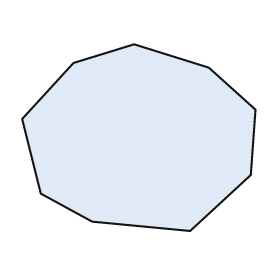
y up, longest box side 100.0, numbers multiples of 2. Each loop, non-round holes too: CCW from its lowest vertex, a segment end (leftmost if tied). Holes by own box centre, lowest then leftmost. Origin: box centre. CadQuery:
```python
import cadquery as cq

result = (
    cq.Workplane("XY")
    .moveTo(22.0, -40.0)
    .lineTo(48.0, -16.0)
    .lineTo(50.0, 12.0)
    .lineTo(30.0, 30.0)
    .lineTo(-2.0, 40.0)
    .lineTo(-28.0, 32.0)
    .lineTo(-50.0, 8.0)
    .lineTo(-42.0, -24.0)
    .lineTo(-20.0, -36.0)
    .close()
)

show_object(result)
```